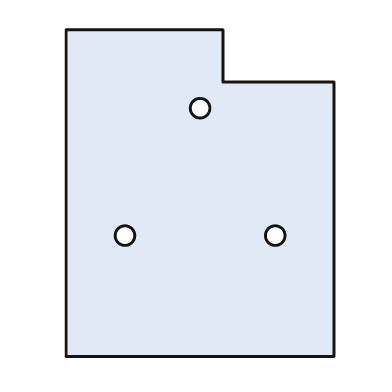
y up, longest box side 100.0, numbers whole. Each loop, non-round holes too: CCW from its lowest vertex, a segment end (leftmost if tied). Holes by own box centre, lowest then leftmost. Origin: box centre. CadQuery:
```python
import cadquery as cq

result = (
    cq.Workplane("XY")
    .moveTo(-41.0, -50.0)
    .lineTo(41.0, -50.0)
    .lineTo(41.0, 34.0)
    .lineTo(7.0, 34.0)
    .lineTo(7.0, 50.0)
    .lineTo(-41.0, 50.0)
    .close()
    .moveTo(-23.0, -13.0)
    .circle(3.0)
    .moveTo(23.0, -13.0)
    .circle(3.0)
    .moveTo(0.0, 26.0)
    .circle(3.0)
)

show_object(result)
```